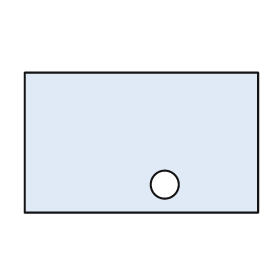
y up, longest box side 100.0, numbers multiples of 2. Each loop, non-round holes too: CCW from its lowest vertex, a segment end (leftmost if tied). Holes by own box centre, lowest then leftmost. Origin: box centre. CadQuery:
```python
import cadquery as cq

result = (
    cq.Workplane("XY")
    .moveTo(-50.0, -30.0)
    .lineTo(50.0, -30.0)
    .lineTo(50.0, 30.0)
    .lineTo(-50.0, 30.0)
    .close()
    .moveTo(10.0, -18.0)
    .circle(6.0)
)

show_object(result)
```